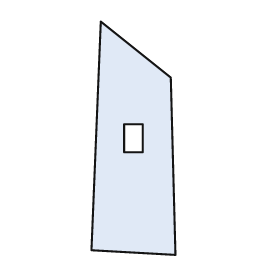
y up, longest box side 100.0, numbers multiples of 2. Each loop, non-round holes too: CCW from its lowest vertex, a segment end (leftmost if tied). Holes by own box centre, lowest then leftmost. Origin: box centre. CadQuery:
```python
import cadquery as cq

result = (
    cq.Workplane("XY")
    .moveTo(18.0, -50.0)
    .lineTo(16.0, 26.0)
    .lineTo(-14.0, 50.0)
    .lineTo(-18.0, -48.0)
    .close()
    .moveTo(-4.0, -6.0)
    .lineTo(4.0, -6.0)
    .lineTo(4.0, 6.0)
    .lineTo(-4.0, 6.0)
    .close()
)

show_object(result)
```